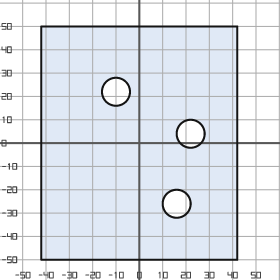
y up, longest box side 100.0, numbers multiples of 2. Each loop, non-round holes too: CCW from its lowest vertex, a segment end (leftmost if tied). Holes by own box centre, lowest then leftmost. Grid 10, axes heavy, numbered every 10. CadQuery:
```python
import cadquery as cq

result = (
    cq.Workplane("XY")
    .moveTo(-42.0, -50.0)
    .lineTo(42.0, -50.0)
    .lineTo(42.0, 50.0)
    .lineTo(-42.0, 50.0)
    .close()
    .moveTo(16.0, -26.0)
    .circle(6.0)
    .moveTo(22.0, 4.0)
    .circle(6.0)
    .moveTo(-10.0, 22.0)
    .circle(6.0)
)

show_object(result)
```